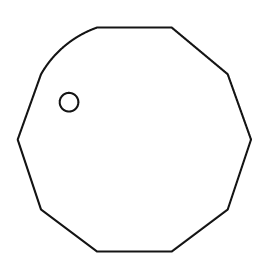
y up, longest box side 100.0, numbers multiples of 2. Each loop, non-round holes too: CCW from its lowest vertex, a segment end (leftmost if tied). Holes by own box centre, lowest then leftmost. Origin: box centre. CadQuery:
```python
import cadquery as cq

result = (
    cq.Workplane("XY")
    .moveTo(-16.0, -48.0)
    .lineTo(16.0, -48.0)
    .lineTo(40.0, -30.0)
    .lineTo(50.0, 0.0)
    .lineTo(40.0, 28.0)
    .lineTo(16.0, 48.0)
    .lineTo(-16.0, 48.0)
    .threePointArc((-30.0, 40.0), (-40.0, 28.0))
    .lineTo(-50.0, 0.0)
    .lineTo(-40.0, -30.0)
    .close()
    .moveTo(-28.0, 16.0)
    .circle(4.0)
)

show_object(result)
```